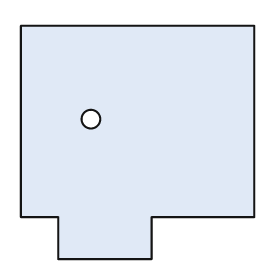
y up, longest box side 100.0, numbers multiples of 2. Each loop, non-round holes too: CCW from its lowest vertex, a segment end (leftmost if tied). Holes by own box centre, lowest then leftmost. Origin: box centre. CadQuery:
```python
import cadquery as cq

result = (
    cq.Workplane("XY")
    .moveTo(-34.0, -50.0)
    .lineTo(6.0, -50.0)
    .lineTo(6.0, -32.0)
    .lineTo(50.0, -32.0)
    .lineTo(50.0, 50.0)
    .lineTo(-50.0, 50.0)
    .lineTo(-50.0, -32.0)
    .lineTo(-34.0, -32.0)
    .close()
    .moveTo(-20.0, 10.0)
    .circle(4.0)
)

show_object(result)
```